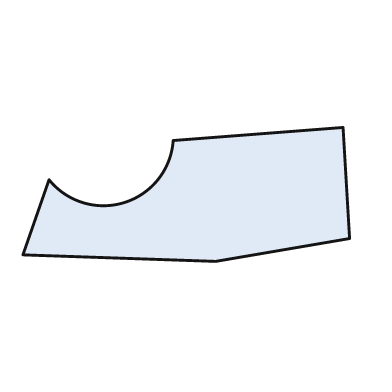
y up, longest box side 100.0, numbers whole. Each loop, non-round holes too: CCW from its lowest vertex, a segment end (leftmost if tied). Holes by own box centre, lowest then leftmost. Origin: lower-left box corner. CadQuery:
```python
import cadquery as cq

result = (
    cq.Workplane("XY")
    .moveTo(59.0, 0.0)
    .lineTo(100.0, 7.0)
    .lineTo(98.0, 41.0)
    .lineTo(46.0, 37.0)
    .threePointArc((31.0, 18.0), (8.0, 25.0))
    .lineTo(0.0, 2.0)
    .close()
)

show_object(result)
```